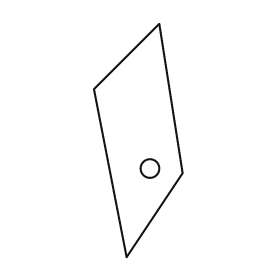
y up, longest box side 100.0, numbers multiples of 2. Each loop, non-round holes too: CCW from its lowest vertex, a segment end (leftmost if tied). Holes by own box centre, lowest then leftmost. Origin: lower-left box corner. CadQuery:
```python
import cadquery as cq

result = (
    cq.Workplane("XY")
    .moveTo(14.0, 0.0)
    .lineTo(38.0, 36.0)
    .lineTo(28.0, 100.0)
    .lineTo(0.0, 72.0)
    .close()
    .moveTo(24.0, 38.0)
    .circle(4.0)
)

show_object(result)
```